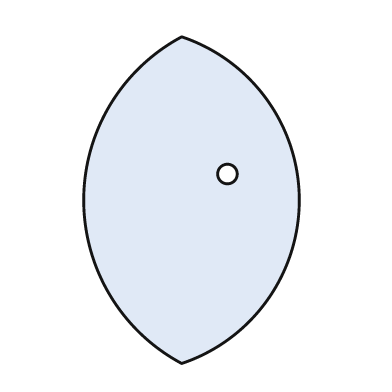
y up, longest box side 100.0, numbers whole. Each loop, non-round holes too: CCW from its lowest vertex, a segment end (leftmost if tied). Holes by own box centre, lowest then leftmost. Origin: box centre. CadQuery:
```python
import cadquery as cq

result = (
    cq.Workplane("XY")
    .moveTo(-3.0, -50.0)
    .threePointArc((33.0, 0.0), (-3.0, 50.0))
    .threePointArc((-33.0, 0.0), (-3.0, -50.0))
    .close()
    .moveTo(11.0, 8.0)
    .circle(3.0)
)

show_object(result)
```